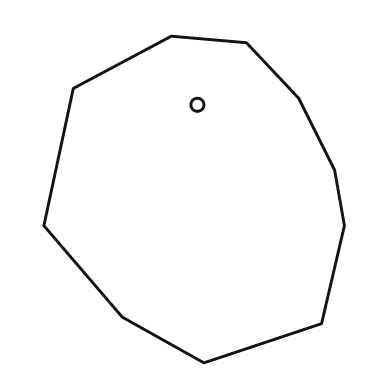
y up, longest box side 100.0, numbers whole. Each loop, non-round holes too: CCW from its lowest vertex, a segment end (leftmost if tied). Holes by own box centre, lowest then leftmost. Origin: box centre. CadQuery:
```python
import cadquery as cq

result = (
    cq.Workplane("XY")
    .moveTo(3.0, -50.0)
    .lineTo(39.0, -38.0)
    .lineTo(46.0, -8.0)
    .lineTo(43.0, 9.0)
    .lineTo(32.0, 31.0)
    .lineTo(16.0, 48.0)
    .lineTo(-7.0, 50.0)
    .lineTo(-37.0, 34.0)
    .lineTo(-46.0, -8.0)
    .lineTo(-22.0, -36.0)
    .close()
    .moveTo(1.0, 29.0)
    .circle(2.0)
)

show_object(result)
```